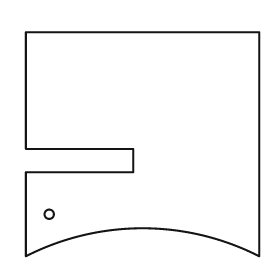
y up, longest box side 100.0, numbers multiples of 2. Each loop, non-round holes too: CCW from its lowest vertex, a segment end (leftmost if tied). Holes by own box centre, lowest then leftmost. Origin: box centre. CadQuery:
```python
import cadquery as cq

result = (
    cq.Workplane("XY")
    .moveTo(-50.0, -48.0)
    .threePointArc((0.0, -36.0), (50.0, -48.0))
    .lineTo(50.0, 48.0)
    .lineTo(-50.0, 48.0)
    .lineTo(-50.0, -2.0)
    .lineTo(-4.0, -2.0)
    .lineTo(-4.0, -12.0)
    .lineTo(-50.0, -12.0)
    .close()
    .moveTo(-40.0, -30.0)
    .circle(2.0)
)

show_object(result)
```